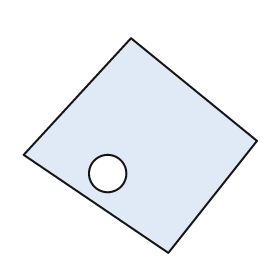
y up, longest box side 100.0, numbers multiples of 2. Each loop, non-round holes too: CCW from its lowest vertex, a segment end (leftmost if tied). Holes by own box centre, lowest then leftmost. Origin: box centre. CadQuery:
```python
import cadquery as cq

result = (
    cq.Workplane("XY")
    .moveTo(12.0, -46.0)
    .lineTo(50.0, 2.0)
    .lineTo(-4.0, 46.0)
    .lineTo(-50.0, -4.0)
    .close()
    .moveTo(-14.0, -12.0)
    .circle(8.0)
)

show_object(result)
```